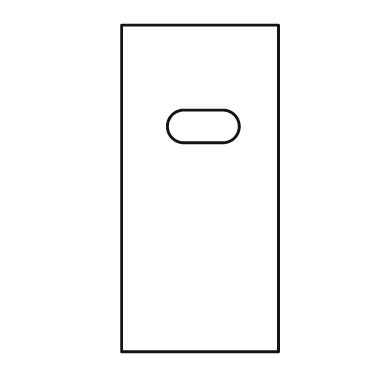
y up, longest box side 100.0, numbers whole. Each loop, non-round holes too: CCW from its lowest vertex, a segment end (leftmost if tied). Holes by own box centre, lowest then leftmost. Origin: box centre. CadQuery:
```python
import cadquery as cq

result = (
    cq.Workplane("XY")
    .moveTo(-24.0, -50.0)
    .lineTo(24.0, -50.0)
    .lineTo(24.0, 50.0)
    .lineTo(-24.0, 50.0)
    .close()
    .moveTo(-5.0, 14.0)
    .lineTo(7.0, 14.0)
    .threePointArc((12.0, 19.0), (7.0, 24.0))
    .lineTo(-5.0, 24.0)
    .threePointArc((-10.0, 19.0), (-5.0, 14.0))
    .close()
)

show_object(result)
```